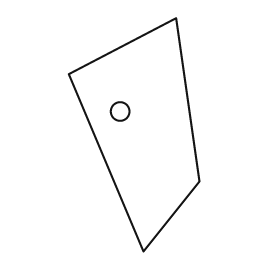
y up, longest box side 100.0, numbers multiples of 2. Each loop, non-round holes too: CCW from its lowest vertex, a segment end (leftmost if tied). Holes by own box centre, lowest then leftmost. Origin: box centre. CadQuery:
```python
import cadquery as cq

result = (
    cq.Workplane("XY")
    .moveTo(4.0, -50.0)
    .lineTo(28.0, -20.0)
    .lineTo(18.0, 50.0)
    .lineTo(-28.0, 26.0)
    .close()
    .moveTo(-6.0, 10.0)
    .circle(4.0)
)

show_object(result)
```